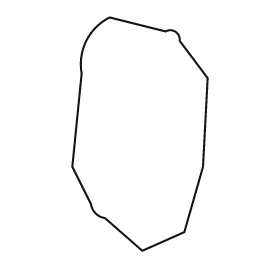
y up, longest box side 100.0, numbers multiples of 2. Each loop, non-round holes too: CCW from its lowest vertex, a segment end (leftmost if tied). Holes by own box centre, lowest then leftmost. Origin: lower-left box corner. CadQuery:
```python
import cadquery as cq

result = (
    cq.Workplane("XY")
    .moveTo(30.0, 0.0)
    .lineTo(48.0, 8.0)
    .lineTo(56.0, 36.0)
    .lineTo(58.0, 74.0)
    .lineTo(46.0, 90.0)
    .threePointArc((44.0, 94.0), (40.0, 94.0))
    .lineTo(16.0, 100.0)
    .threePointArc((6.0, 90.0), (4.0, 76.0))
    .lineTo(0.0, 36.0)
    .lineTo(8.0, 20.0)
    .threePointArc((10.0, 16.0), (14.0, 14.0))
    .close()
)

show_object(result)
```